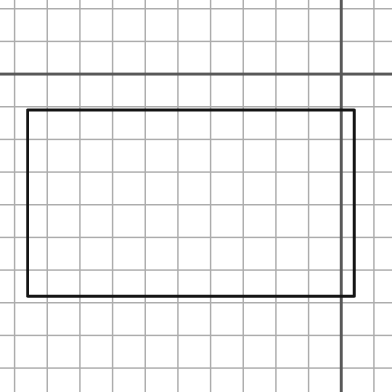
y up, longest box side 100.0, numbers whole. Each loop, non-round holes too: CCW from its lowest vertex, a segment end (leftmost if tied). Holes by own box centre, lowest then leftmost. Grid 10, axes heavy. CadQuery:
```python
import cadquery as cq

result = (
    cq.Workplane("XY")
    .moveTo(-96.0, -68.0)
    .lineTo(4.0, -68.0)
    .lineTo(4.0, -11.0)
    .lineTo(-96.0, -11.0)
    .close()
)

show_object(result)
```